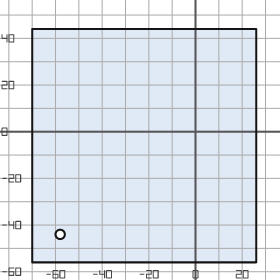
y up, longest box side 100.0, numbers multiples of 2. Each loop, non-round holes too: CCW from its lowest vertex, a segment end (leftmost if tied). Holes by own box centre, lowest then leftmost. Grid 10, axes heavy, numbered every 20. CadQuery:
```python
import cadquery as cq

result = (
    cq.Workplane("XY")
    .moveTo(-70.0, -56.0)
    .lineTo(26.0, -56.0)
    .lineTo(26.0, 44.0)
    .lineTo(-70.0, 44.0)
    .close()
    .moveTo(-58.0, -44.0)
    .circle(2.0)
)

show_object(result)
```